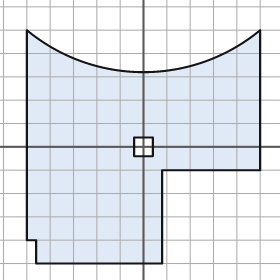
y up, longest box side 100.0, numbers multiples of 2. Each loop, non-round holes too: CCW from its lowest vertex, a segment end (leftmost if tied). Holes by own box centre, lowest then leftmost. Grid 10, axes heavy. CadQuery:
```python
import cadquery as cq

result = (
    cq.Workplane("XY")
    .moveTo(-46.0, -50.0)
    .lineTo(8.0, -50.0)
    .lineTo(8.0, -10.0)
    .lineTo(50.0, -10.0)
    .lineTo(50.0, 50.0)
    .threePointArc((0.0, 32.0), (-50.0, 50.0))
    .lineTo(-50.0, -40.0)
    .lineTo(-46.0, -40.0)
    .close()
    .moveTo(-4.0, -4.0)
    .lineTo(4.0, -4.0)
    .lineTo(4.0, 4.0)
    .lineTo(-4.0, 4.0)
    .close()
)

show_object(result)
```